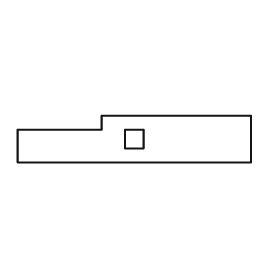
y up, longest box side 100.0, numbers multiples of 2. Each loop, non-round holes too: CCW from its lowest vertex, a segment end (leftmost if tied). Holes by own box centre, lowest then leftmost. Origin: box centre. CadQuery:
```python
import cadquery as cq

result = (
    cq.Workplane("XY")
    .moveTo(-50.0, -10.0)
    .lineTo(50.0, -10.0)
    .lineTo(50.0, 10.0)
    .lineTo(-14.0, 10.0)
    .lineTo(-14.0, 4.0)
    .lineTo(-50.0, 4.0)
    .close()
    .moveTo(-4.0, -4.0)
    .lineTo(4.0, -4.0)
    .lineTo(4.0, 4.0)
    .lineTo(-4.0, 4.0)
    .close()
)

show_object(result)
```